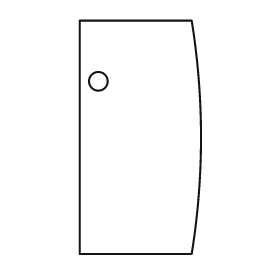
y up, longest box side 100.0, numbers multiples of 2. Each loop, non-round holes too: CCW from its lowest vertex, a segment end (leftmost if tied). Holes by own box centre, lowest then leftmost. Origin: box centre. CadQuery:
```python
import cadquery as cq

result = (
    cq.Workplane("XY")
    .moveTo(-26.0, -50.0)
    .lineTo(22.0, -50.0)
    .threePointArc((26.0, 0.0), (22.0, 50.0))
    .lineTo(-26.0, 50.0)
    .close()
    .moveTo(-18.0, 24.0)
    .circle(4.0)
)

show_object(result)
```